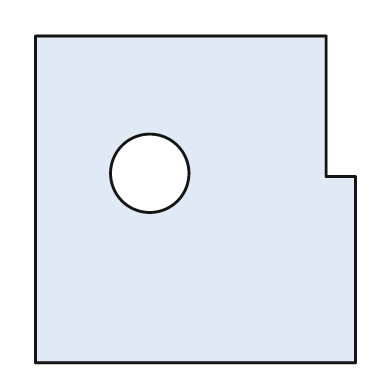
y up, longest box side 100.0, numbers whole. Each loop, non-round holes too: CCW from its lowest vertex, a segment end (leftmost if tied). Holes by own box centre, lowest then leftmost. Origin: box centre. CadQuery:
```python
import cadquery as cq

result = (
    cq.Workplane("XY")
    .moveTo(-49.0, -50.0)
    .lineTo(49.0, -50.0)
    .lineTo(49.0, 7.0)
    .lineTo(40.0, 7.0)
    .lineTo(40.0, 50.0)
    .lineTo(-49.0, 50.0)
    .close()
    .moveTo(-14.0, 8.0)
    .circle(12.0)
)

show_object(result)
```